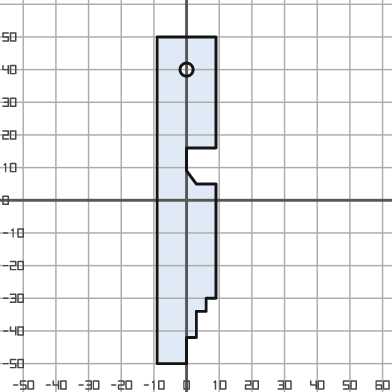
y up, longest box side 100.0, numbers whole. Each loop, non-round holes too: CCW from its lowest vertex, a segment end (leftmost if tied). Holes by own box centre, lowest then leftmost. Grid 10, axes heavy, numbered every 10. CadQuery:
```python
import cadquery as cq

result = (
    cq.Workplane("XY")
    .moveTo(-9.0, -50.0)
    .lineTo(0.0, -50.0)
    .lineTo(0.0, -42.0)
    .lineTo(3.0, -42.0)
    .lineTo(3.0, -34.0)
    .lineTo(6.0, -34.0)
    .lineTo(6.0, -30.0)
    .lineTo(9.0, -30.0)
    .lineTo(9.0, 5.0)
    .lineTo(3.0, 5.0)
    .lineTo(0.0, 9.0)
    .lineTo(0.0, 16.0)
    .lineTo(9.0, 16.0)
    .lineTo(9.0, 50.0)
    .lineTo(-9.0, 50.0)
    .close()
    .moveTo(0.0, 40.0)
    .circle(2.0)
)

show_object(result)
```